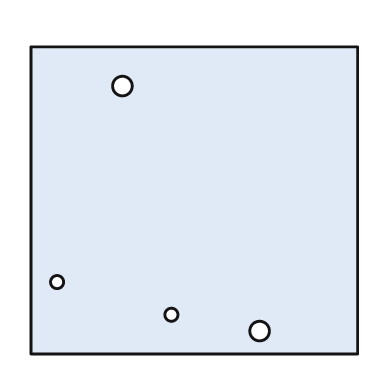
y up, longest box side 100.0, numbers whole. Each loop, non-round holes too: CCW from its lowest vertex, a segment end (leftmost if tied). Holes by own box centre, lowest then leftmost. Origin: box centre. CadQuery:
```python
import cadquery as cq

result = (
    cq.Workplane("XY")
    .moveTo(-50.0, -47.0)
    .lineTo(50.0, -47.0)
    .lineTo(50.0, 47.0)
    .lineTo(-50.0, 47.0)
    .close()
    .moveTo(20.0, -40.0)
    .circle(3.0)
    .moveTo(-7.0, -35.0)
    .circle(2.0)
    .moveTo(-42.0, -25.0)
    .circle(2.0)
    .moveTo(-22.0, 35.0)
    .circle(3.0)
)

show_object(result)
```